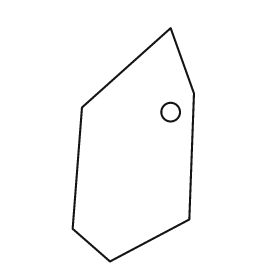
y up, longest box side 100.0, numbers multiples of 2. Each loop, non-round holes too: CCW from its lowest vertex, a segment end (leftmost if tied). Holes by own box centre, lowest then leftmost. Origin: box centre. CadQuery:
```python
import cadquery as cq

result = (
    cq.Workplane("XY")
    .moveTo(-10.0, -50.0)
    .lineTo(24.0, -32.0)
    .lineTo(26.0, 22.0)
    .lineTo(16.0, 50.0)
    .lineTo(-22.0, 16.0)
    .lineTo(-26.0, -36.0)
    .close()
    .moveTo(16.0, 14.0)
    .circle(4.0)
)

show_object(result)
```